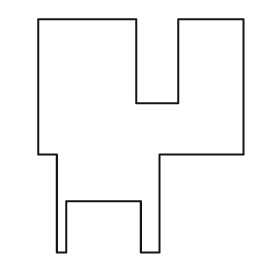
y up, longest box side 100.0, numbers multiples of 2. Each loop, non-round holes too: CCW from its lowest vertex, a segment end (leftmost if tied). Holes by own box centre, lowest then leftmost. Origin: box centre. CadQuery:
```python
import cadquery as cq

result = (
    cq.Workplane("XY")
    .moveTo(-36.0, -50.0)
    .lineTo(-32.0, -50.0)
    .lineTo(-32.0, -28.0)
    .lineTo(0.0, -28.0)
    .lineTo(0.0, -50.0)
    .lineTo(8.0, -50.0)
    .lineTo(8.0, -8.0)
    .lineTo(44.0, -8.0)
    .lineTo(44.0, 50.0)
    .lineTo(16.0, 50.0)
    .lineTo(16.0, 14.0)
    .lineTo(-2.0, 14.0)
    .lineTo(-2.0, 50.0)
    .lineTo(-44.0, 50.0)
    .lineTo(-44.0, -8.0)
    .lineTo(-36.0, -8.0)
    .close()
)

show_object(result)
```